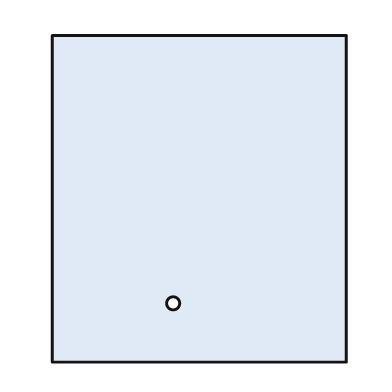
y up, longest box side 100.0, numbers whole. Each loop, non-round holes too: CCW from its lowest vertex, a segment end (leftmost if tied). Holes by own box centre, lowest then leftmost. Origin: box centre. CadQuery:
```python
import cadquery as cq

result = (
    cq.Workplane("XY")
    .moveTo(-45.0, -50.0)
    .lineTo(45.0, -50.0)
    .lineTo(45.0, 50.0)
    .lineTo(-45.0, 50.0)
    .close()
    .moveTo(-8.0, -32.0)
    .circle(2.0)
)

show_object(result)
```